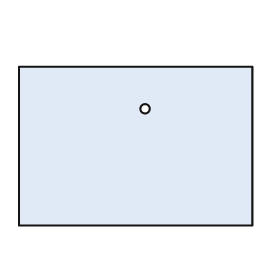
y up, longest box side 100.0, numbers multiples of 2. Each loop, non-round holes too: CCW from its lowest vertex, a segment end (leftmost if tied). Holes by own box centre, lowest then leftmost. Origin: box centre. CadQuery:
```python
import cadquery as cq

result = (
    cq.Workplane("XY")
    .moveTo(-50.0, -34.0)
    .lineTo(50.0, -34.0)
    .lineTo(50.0, 34.0)
    .lineTo(-50.0, 34.0)
    .close()
    .moveTo(4.0, 16.0)
    .circle(2.0)
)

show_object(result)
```